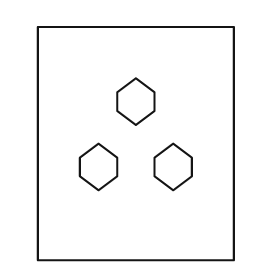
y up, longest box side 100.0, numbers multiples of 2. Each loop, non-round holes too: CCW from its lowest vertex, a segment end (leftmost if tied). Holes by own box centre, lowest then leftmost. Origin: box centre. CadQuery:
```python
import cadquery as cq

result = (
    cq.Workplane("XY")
    .moveTo(-42.0, -50.0)
    .lineTo(42.0, -50.0)
    .lineTo(42.0, 50.0)
    .lineTo(-42.0, 50.0)
    .close()
    .moveTo(-16.0, -20.0)
    .lineTo(-8.0, -14.0)
    .lineTo(-8.0, -6.0)
    .lineTo(-16.0, 0.0)
    .lineTo(-24.0, -6.0)
    .lineTo(-24.0, -14.0)
    .close()
    .moveTo(16.0, -20.0)
    .lineTo(24.0, -14.0)
    .lineTo(24.0, -6.0)
    .lineTo(16.0, 0.0)
    .lineTo(8.0, -6.0)
    .lineTo(8.0, -14.0)
    .close()
    .moveTo(0.0, 8.0)
    .lineTo(8.0, 14.0)
    .lineTo(8.0, 22.0)
    .lineTo(0.0, 28.0)
    .lineTo(-8.0, 22.0)
    .lineTo(-8.0, 14.0)
    .close()
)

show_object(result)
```